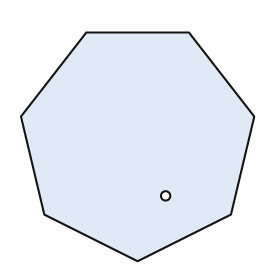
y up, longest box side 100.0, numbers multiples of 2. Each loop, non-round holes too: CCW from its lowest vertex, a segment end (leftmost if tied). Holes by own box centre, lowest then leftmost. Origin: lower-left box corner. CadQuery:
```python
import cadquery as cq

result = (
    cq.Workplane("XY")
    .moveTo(50.0, 0.0)
    .lineTo(90.0, 20.0)
    .lineTo(100.0, 62.0)
    .lineTo(72.0, 98.0)
    .lineTo(28.0, 98.0)
    .lineTo(0.0, 62.0)
    .lineTo(10.0, 20.0)
    .close()
    .moveTo(62.0, 28.0)
    .circle(2.0)
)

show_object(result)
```